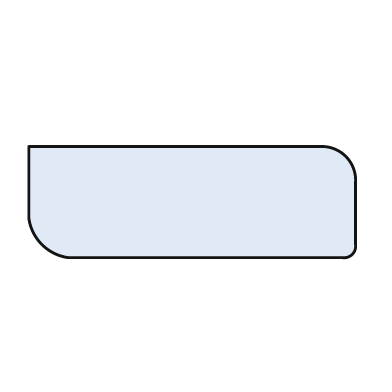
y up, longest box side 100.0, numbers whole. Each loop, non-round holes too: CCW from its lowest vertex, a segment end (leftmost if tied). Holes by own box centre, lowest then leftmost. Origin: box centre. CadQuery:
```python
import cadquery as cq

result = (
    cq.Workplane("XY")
    .moveTo(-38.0, -17.0)
    .lineTo(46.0, -17.0)
    .threePointArc((49.0, -16.0), (50.0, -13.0))
    .lineTo(50.0, 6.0)
    .threePointArc((47.0, 14.0), (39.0, 17.0))
    .lineTo(-50.0, 17.0)
    .lineTo(-50.0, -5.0)
    .threePointArc((-46.0, -13.0), (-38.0, -17.0))
    .close()
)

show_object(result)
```